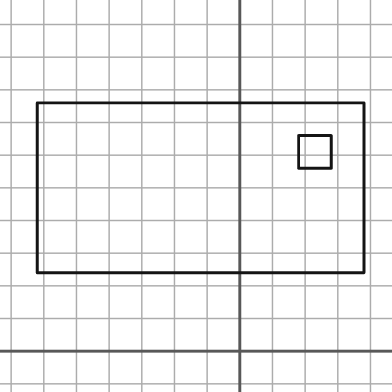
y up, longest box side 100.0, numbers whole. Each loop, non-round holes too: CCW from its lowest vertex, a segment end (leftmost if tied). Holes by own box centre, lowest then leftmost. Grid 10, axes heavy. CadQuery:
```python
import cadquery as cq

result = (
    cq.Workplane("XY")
    .moveTo(-62.0, 24.0)
    .lineTo(38.0, 24.0)
    .lineTo(38.0, 76.0)
    .lineTo(-62.0, 76.0)
    .close()
    .moveTo(18.0, 56.0)
    .lineTo(28.0, 56.0)
    .lineTo(28.0, 66.0)
    .lineTo(18.0, 66.0)
    .close()
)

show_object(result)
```